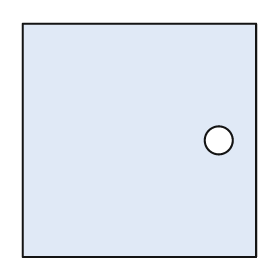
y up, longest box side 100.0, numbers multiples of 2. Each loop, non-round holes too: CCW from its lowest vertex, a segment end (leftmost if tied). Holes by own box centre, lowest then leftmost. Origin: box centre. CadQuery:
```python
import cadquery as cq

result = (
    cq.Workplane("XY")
    .moveTo(-50.0, -50.0)
    .lineTo(50.0, -50.0)
    .lineTo(50.0, 50.0)
    .lineTo(-50.0, 50.0)
    .close()
    .moveTo(34.0, 0.0)
    .circle(6.0)
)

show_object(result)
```